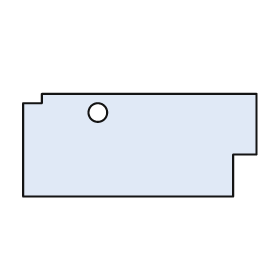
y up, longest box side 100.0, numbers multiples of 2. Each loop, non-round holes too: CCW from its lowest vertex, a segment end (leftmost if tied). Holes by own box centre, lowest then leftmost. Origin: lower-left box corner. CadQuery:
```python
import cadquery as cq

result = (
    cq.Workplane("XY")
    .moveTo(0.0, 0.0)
    .lineTo(90.0, 0.0)
    .lineTo(90.0, 18.0)
    .lineTo(100.0, 18.0)
    .lineTo(100.0, 44.0)
    .lineTo(8.0, 44.0)
    .lineTo(8.0, 40.0)
    .lineTo(0.0, 40.0)
    .close()
    .moveTo(32.0, 36.0)
    .circle(4.0)
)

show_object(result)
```